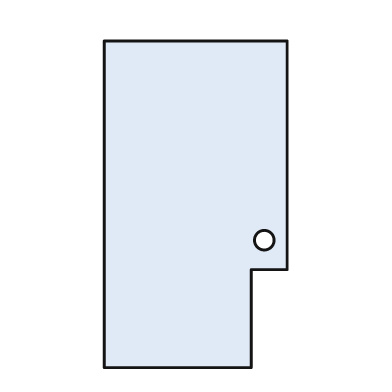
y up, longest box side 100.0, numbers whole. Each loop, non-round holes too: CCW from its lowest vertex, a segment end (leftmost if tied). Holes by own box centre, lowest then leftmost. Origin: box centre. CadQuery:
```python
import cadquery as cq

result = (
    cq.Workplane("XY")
    .moveTo(-28.0, -50.0)
    .lineTo(17.0, -50.0)
    .lineTo(17.0, -20.0)
    .lineTo(28.0, -20.0)
    .lineTo(28.0, 50.0)
    .lineTo(-28.0, 50.0)
    .close()
    .moveTo(21.0, -11.0)
    .circle(3.0)
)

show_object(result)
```